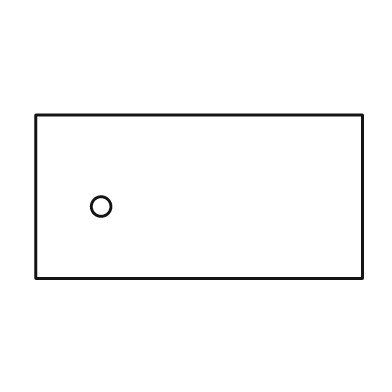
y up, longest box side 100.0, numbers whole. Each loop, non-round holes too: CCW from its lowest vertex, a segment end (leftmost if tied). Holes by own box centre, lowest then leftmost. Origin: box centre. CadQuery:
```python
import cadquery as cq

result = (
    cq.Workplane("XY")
    .moveTo(-50.0, -25.0)
    .lineTo(50.0, -25.0)
    .lineTo(50.0, 25.0)
    .lineTo(-50.0, 25.0)
    .close()
    .moveTo(-30.0, -3.0)
    .circle(3.0)
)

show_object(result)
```